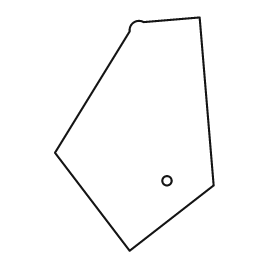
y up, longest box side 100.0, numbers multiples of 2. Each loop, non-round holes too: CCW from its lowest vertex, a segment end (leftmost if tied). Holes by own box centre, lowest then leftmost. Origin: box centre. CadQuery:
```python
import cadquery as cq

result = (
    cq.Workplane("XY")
    .moveTo(-2.0, -50.0)
    .lineTo(34.0, -22.0)
    .lineTo(28.0, 50.0)
    .lineTo(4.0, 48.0)
    .threePointArc((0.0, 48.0), (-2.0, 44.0))
    .lineTo(-34.0, -8.0)
    .close()
    .moveTo(14.0, -20.0)
    .circle(2.0)
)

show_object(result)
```